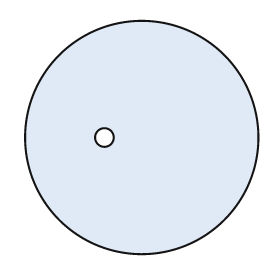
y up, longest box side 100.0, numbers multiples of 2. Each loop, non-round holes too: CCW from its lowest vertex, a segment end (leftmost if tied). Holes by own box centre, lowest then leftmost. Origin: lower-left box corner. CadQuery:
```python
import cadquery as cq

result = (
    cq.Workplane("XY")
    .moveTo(50.0, 50.0)
    .circle(50.0)
    .moveTo(34.0, 50.0)
    .circle(4.0)
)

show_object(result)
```